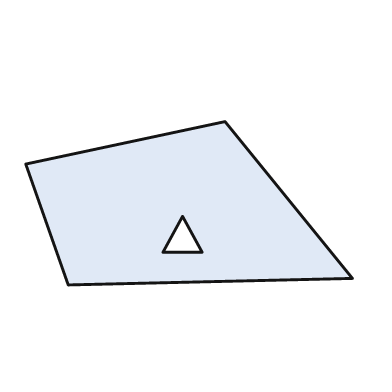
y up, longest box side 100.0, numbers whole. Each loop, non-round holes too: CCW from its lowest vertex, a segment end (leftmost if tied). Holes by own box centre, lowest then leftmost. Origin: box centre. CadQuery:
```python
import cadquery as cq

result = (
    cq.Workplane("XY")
    .moveTo(-37.0, -25.0)
    .lineTo(50.0, -23.0)
    .lineTo(11.0, 25.0)
    .lineTo(-50.0, 12.0)
    .close()
    .moveTo(-8.0, -15.0)
    .lineTo(4.0, -15.0)
    .lineTo(-2.0, -4.0)
    .close()
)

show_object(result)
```